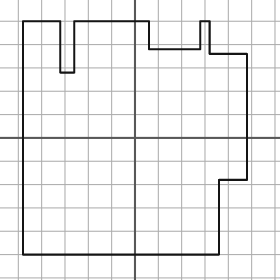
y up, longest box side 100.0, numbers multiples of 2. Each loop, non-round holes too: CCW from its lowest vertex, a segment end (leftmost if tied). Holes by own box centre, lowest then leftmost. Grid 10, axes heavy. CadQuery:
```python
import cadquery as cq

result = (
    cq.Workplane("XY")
    .moveTo(-48.0, -50.0)
    .lineTo(36.0, -50.0)
    .lineTo(36.0, -18.0)
    .lineTo(48.0, -18.0)
    .lineTo(48.0, 36.0)
    .lineTo(32.0, 36.0)
    .lineTo(32.0, 50.0)
    .lineTo(28.0, 50.0)
    .lineTo(28.0, 38.0)
    .lineTo(6.0, 38.0)
    .lineTo(6.0, 50.0)
    .lineTo(-26.0, 50.0)
    .lineTo(-26.0, 28.0)
    .lineTo(-32.0, 28.0)
    .lineTo(-32.0, 50.0)
    .lineTo(-48.0, 50.0)
    .close()
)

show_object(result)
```